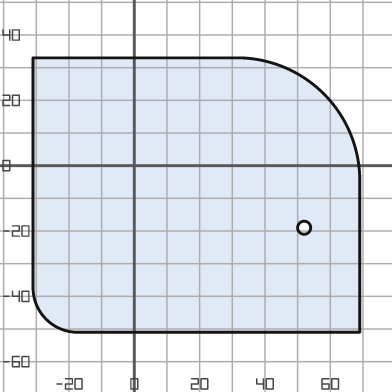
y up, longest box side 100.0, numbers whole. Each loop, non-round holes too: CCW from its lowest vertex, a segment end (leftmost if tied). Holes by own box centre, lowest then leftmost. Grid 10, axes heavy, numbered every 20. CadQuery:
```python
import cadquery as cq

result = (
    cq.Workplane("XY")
    .moveTo(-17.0, -51.0)
    .lineTo(69.0, -51.0)
    .lineTo(69.0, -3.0)
    .threePointArc((58.0, 22.0), (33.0, 33.0))
    .lineTo(-31.0, 33.0)
    .lineTo(-31.0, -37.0)
    .threePointArc((-27.0, -47.0), (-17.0, -51.0))
    .close()
    .moveTo(52.0, -19.0)
    .circle(2.0)
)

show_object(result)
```